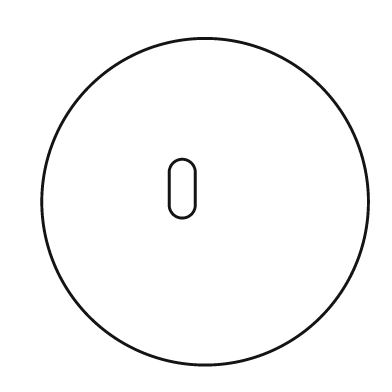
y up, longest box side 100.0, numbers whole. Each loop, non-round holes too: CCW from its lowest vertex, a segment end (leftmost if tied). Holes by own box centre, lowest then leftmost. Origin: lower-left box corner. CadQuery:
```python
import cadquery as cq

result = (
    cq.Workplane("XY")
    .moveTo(50.0, 50.0)
    .circle(50.0)
    .moveTo(39.0, 49.0)
    .threePointArc((43.0, 45.0), (47.0, 49.0))
    .lineTo(47.0, 59.0)
    .threePointArc((43.0, 63.0), (39.0, 59.0))
    .close()
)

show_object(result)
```